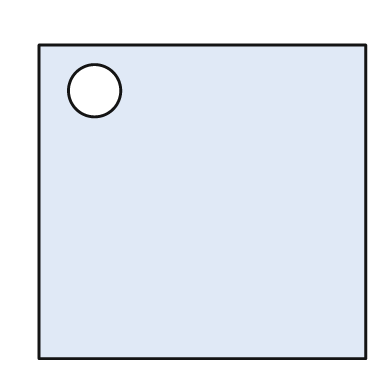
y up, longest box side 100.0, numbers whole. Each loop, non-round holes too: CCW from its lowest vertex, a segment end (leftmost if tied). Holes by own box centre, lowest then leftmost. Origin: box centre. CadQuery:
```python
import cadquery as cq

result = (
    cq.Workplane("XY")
    .moveTo(-50.0, -48.0)
    .lineTo(50.0, -48.0)
    .lineTo(50.0, 48.0)
    .lineTo(-50.0, 48.0)
    .close()
    .moveTo(-33.0, 34.0)
    .circle(8.0)
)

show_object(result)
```